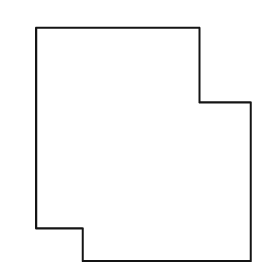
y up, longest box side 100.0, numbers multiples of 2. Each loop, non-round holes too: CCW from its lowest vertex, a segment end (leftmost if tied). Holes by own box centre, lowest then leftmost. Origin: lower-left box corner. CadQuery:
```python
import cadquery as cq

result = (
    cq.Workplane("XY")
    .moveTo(20.0, 0.0)
    .lineTo(92.0, 0.0)
    .lineTo(92.0, 68.0)
    .lineTo(70.0, 68.0)
    .lineTo(70.0, 100.0)
    .lineTo(0.0, 100.0)
    .lineTo(0.0, 14.0)
    .lineTo(20.0, 14.0)
    .close()
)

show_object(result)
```